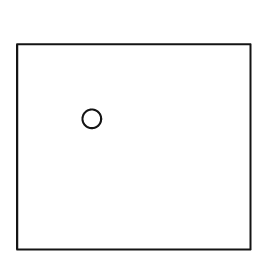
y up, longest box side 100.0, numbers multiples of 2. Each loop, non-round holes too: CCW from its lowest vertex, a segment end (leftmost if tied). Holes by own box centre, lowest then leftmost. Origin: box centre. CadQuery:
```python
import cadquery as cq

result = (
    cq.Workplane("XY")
    .moveTo(-50.0, -44.0)
    .lineTo(50.0, -44.0)
    .lineTo(50.0, 44.0)
    .lineTo(-50.0, 44.0)
    .close()
    .moveTo(-18.0, 12.0)
    .circle(4.0)
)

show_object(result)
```